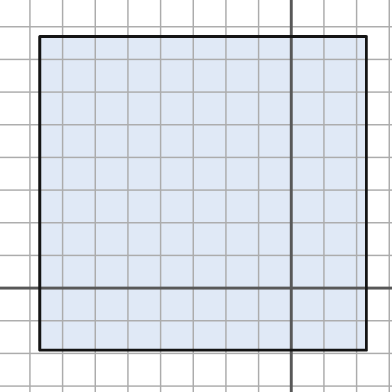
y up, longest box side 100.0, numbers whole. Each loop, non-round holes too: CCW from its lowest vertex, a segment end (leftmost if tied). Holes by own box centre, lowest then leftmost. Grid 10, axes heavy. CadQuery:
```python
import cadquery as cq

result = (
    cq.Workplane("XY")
    .moveTo(-77.0, -19.0)
    .lineTo(23.0, -19.0)
    .lineTo(23.0, 77.0)
    .lineTo(-77.0, 77.0)
    .close()
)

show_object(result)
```